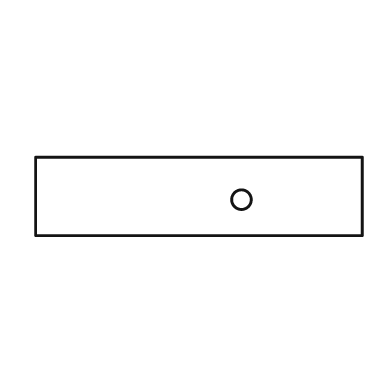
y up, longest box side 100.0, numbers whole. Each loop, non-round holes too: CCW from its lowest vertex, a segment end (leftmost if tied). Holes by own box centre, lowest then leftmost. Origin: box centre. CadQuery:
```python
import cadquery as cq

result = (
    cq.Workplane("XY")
    .moveTo(-50.0, -12.0)
    .lineTo(50.0, -12.0)
    .lineTo(50.0, 12.0)
    .lineTo(-50.0, 12.0)
    .close()
    .moveTo(13.0, -1.0)
    .circle(3.0)
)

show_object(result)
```